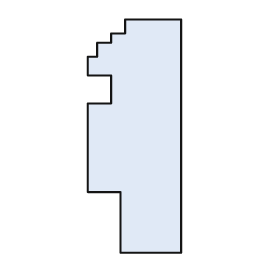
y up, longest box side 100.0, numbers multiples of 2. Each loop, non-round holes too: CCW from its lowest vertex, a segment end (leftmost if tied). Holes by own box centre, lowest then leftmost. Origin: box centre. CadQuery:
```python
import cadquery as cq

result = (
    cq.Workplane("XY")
    .moveTo(-6.0, -50.0)
    .lineTo(20.0, -50.0)
    .lineTo(20.0, 50.0)
    .lineTo(-4.0, 50.0)
    .lineTo(-4.0, 44.0)
    .lineTo(-10.0, 44.0)
    .lineTo(-10.0, 40.0)
    .lineTo(-16.0, 40.0)
    .lineTo(-16.0, 34.0)
    .lineTo(-20.0, 34.0)
    .lineTo(-20.0, 26.0)
    .lineTo(-10.0, 26.0)
    .lineTo(-10.0, 14.0)
    .lineTo(-20.0, 14.0)
    .lineTo(-20.0, -24.0)
    .lineTo(-6.0, -24.0)
    .close()
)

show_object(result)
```